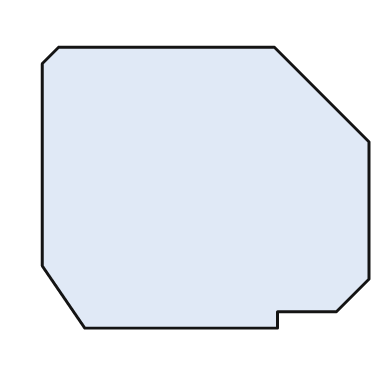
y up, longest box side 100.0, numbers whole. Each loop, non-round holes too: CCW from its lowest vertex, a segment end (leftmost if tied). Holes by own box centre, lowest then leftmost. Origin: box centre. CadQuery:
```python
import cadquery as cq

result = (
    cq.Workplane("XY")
    .moveTo(-37.0, -43.0)
    .lineTo(22.0, -43.0)
    .lineTo(22.0, -38.0)
    .lineTo(40.0, -38.0)
    .lineTo(50.0, -28.0)
    .lineTo(50.0, 14.0)
    .lineTo(21.0, 43.0)
    .lineTo(-45.0, 43.0)
    .lineTo(-50.0, 38.0)
    .lineTo(-50.0, -24.0)
    .close()
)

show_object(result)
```